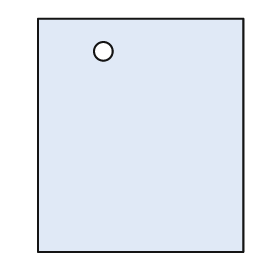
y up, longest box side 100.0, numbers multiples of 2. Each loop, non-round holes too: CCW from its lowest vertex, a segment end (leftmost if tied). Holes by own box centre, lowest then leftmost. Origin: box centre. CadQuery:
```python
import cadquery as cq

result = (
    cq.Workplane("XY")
    .moveTo(-44.0, -50.0)
    .lineTo(44.0, -50.0)
    .lineTo(44.0, 50.0)
    .lineTo(-44.0, 50.0)
    .close()
    .moveTo(-16.0, 36.0)
    .circle(4.0)
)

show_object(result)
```